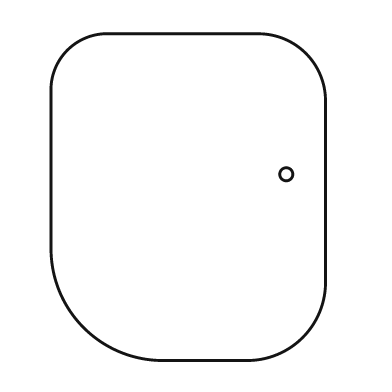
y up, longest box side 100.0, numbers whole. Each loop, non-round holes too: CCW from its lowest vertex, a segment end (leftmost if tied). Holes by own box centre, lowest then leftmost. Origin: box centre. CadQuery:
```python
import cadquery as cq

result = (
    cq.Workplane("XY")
    .moveTo(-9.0, -50.0)
    .lineTo(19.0, -50.0)
    .threePointArc((35.0, -43.0), (42.0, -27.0))
    .lineTo(42.0, 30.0)
    .threePointArc((36.0, 44.0), (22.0, 50.0))
    .lineTo(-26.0, 50.0)
    .threePointArc((-37.0, 45.0), (-42.0, 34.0))
    .lineTo(-42.0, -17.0)
    .threePointArc((-32.0, -40.0), (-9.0, -50.0))
    .close()
    .moveTo(30.0, 7.0)
    .circle(2.0)
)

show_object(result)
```